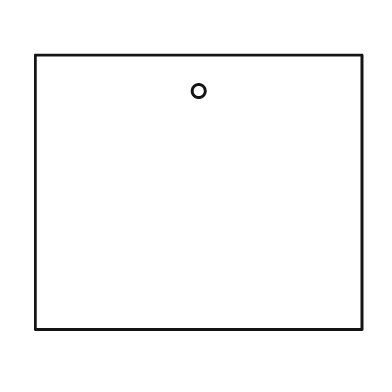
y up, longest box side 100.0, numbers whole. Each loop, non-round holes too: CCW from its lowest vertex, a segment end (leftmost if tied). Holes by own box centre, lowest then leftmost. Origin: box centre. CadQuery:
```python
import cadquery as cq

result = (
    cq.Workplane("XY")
    .moveTo(-50.0, -42.0)
    .lineTo(50.0, -42.0)
    .lineTo(50.0, 42.0)
    .lineTo(-50.0, 42.0)
    .close()
    .moveTo(0.0, 31.0)
    .circle(2.0)
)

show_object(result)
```